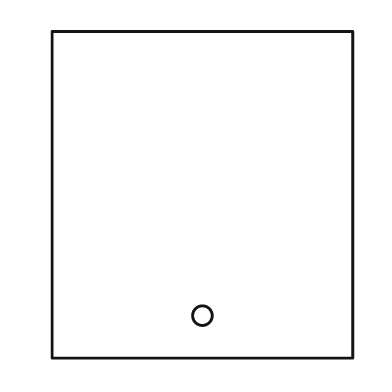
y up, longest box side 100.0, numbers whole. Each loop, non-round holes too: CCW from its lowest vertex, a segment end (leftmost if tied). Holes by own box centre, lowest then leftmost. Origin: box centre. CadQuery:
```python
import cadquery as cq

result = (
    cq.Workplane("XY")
    .moveTo(-46.0, -50.0)
    .lineTo(46.0, -50.0)
    .lineTo(46.0, 50.0)
    .lineTo(-46.0, 50.0)
    .close()
    .moveTo(0.0, -37.0)
    .circle(3.0)
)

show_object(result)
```